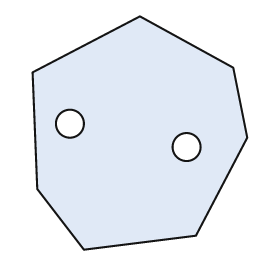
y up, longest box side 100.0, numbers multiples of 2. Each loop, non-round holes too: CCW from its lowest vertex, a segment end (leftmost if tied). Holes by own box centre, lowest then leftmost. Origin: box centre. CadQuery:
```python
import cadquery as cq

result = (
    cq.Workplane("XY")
    .moveTo(-24.0, -50.0)
    .lineTo(24.0, -44.0)
    .lineTo(46.0, -2.0)
    .lineTo(40.0, 28.0)
    .lineTo(0.0, 50.0)
    .lineTo(-46.0, 26.0)
    .lineTo(-44.0, -24.0)
    .close()
    .moveTo(20.0, -6.0)
    .circle(6.0)
    .moveTo(-30.0, 4.0)
    .circle(6.0)
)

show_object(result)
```